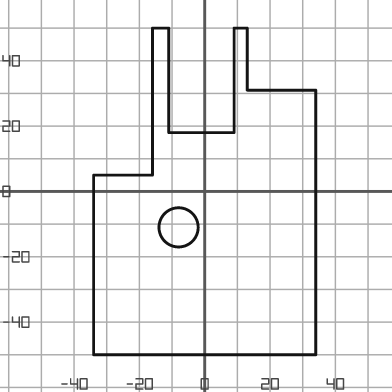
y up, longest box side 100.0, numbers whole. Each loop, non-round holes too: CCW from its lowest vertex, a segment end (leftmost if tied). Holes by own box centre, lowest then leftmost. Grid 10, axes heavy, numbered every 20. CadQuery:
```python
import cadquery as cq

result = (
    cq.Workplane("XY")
    .moveTo(-34.0, -50.0)
    .lineTo(34.0, -50.0)
    .lineTo(34.0, 31.0)
    .lineTo(13.0, 31.0)
    .lineTo(13.0, 50.0)
    .lineTo(9.0, 50.0)
    .lineTo(9.0, 18.0)
    .lineTo(-11.0, 18.0)
    .lineTo(-11.0, 50.0)
    .lineTo(-16.0, 50.0)
    .lineTo(-16.0, 5.0)
    .lineTo(-34.0, 5.0)
    .close()
    .moveTo(-8.0, -11.0)
    .circle(6.0)
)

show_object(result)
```